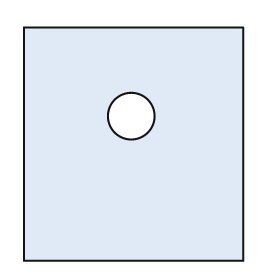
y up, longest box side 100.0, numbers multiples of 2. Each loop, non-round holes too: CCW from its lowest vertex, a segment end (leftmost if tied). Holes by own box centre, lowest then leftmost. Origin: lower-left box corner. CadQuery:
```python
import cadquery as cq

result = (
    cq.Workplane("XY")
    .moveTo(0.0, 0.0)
    .lineTo(94.0, 0.0)
    .lineTo(94.0, 100.0)
    .lineTo(0.0, 100.0)
    .close()
    .moveTo(46.0, 62.0)
    .circle(10.0)
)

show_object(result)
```